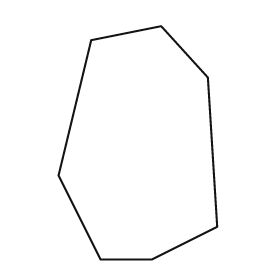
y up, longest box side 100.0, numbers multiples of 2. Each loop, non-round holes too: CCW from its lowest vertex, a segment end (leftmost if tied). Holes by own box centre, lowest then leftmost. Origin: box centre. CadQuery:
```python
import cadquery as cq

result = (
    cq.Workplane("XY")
    .moveTo(-16.0, -50.0)
    .lineTo(6.0, -50.0)
    .lineTo(34.0, -36.0)
    .lineTo(30.0, 28.0)
    .lineTo(10.0, 50.0)
    .lineTo(-20.0, 44.0)
    .lineTo(-34.0, -14.0)
    .close()
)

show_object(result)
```